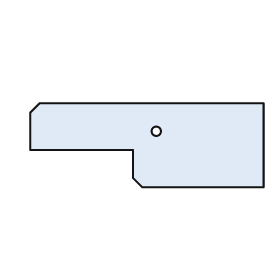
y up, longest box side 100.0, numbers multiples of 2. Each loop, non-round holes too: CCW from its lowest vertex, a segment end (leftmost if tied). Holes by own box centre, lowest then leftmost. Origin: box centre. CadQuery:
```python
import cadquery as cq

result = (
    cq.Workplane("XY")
    .moveTo(-2.0, -18.0)
    .lineTo(50.0, -18.0)
    .lineTo(50.0, 18.0)
    .lineTo(-46.0, 18.0)
    .lineTo(-50.0, 14.0)
    .lineTo(-50.0, -2.0)
    .lineTo(-6.0, -2.0)
    .lineTo(-6.0, -14.0)
    .close()
    .moveTo(4.0, 6.0)
    .circle(2.0)
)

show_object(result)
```